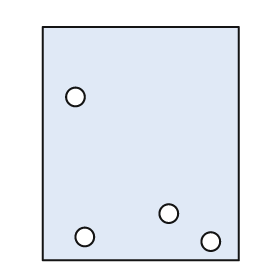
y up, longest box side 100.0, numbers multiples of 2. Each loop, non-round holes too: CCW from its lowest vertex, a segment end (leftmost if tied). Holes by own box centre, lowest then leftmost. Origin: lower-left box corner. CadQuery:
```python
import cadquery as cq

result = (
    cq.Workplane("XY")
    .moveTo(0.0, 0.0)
    .lineTo(84.0, 0.0)
    .lineTo(84.0, 100.0)
    .lineTo(0.0, 100.0)
    .close()
    .moveTo(72.0, 8.0)
    .circle(4.0)
    .moveTo(18.0, 10.0)
    .circle(4.0)
    .moveTo(54.0, 20.0)
    .circle(4.0)
    .moveTo(14.0, 70.0)
    .circle(4.0)
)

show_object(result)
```